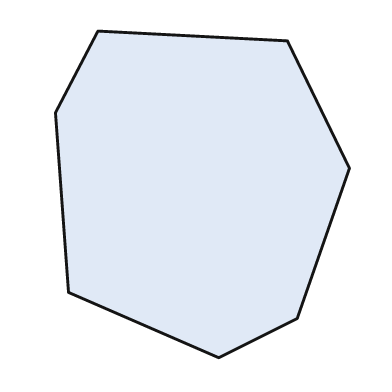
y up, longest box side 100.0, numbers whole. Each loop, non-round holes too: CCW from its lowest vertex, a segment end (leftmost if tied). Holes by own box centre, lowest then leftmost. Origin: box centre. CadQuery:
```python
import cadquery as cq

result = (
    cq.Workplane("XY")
    .moveTo(5.0, -50.0)
    .lineTo(29.0, -38.0)
    .lineTo(45.0, 8.0)
    .lineTo(26.0, 47.0)
    .lineTo(-32.0, 50.0)
    .lineTo(-45.0, 25.0)
    .lineTo(-41.0, -30.0)
    .close()
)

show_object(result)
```